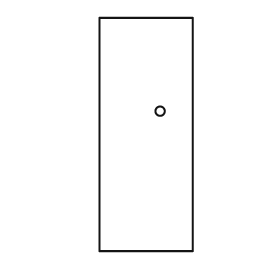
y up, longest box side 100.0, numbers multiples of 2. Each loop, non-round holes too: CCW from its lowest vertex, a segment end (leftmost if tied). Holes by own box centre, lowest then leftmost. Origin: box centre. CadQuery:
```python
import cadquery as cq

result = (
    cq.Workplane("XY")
    .moveTo(-20.0, -50.0)
    .lineTo(20.0, -50.0)
    .lineTo(20.0, 50.0)
    .lineTo(-20.0, 50.0)
    .close()
    .moveTo(6.0, 10.0)
    .circle(2.0)
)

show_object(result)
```